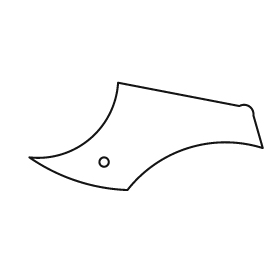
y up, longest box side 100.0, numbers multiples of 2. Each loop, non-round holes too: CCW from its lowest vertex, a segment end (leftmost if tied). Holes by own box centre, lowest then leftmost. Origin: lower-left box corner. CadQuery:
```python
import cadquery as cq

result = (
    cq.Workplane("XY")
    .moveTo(42.0, 0.0)
    .threePointArc((68.0, 18.0), (100.0, 18.0))
    .lineTo(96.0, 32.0)
    .threePointArc((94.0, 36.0), (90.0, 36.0))
    .lineTo(38.0, 46.0)
    .threePointArc((26.0, 22.0), (0.0, 14.0))
    .threePointArc((20.0, 4.0), (42.0, 0.0))
    .close()
    .moveTo(32.0, 12.0)
    .circle(2.0)
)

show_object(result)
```